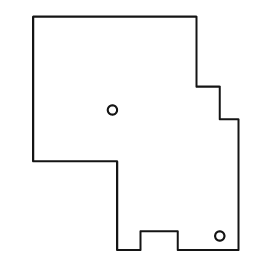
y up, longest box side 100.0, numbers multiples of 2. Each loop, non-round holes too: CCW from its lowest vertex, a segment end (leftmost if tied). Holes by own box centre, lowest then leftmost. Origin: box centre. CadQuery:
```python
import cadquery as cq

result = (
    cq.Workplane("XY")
    .moveTo(-8.0, -50.0)
    .lineTo(2.0, -50.0)
    .lineTo(2.0, -42.0)
    .lineTo(18.0, -42.0)
    .lineTo(18.0, -50.0)
    .lineTo(44.0, -50.0)
    .lineTo(44.0, 6.0)
    .lineTo(36.0, 6.0)
    .lineTo(36.0, 20.0)
    .lineTo(26.0, 20.0)
    .lineTo(26.0, 50.0)
    .lineTo(-44.0, 50.0)
    .lineTo(-44.0, -12.0)
    .lineTo(-8.0, -12.0)
    .close()
    .moveTo(36.0, -44.0)
    .circle(2.0)
    .moveTo(-10.0, 10.0)
    .circle(2.0)
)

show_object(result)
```